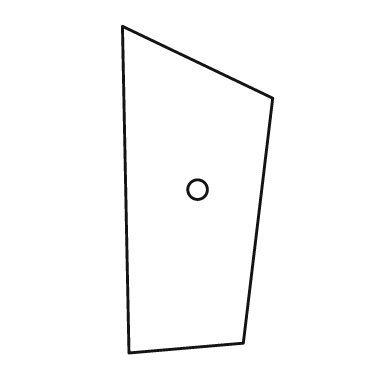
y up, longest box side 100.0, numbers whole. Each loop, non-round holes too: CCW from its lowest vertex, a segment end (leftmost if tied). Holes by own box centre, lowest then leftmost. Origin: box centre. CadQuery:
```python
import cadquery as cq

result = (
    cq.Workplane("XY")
    .moveTo(-21.0, -50.0)
    .lineTo(14.0, -47.0)
    .lineTo(23.0, 28.0)
    .lineTo(-23.0, 50.0)
    .close()
    .moveTo(0.0, 0.0)
    .circle(3.0)
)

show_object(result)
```